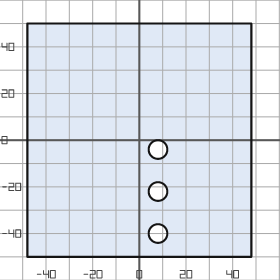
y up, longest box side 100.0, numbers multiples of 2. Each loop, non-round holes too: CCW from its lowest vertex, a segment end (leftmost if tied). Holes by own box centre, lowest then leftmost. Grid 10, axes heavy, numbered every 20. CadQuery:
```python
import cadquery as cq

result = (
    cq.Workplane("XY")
    .moveTo(-48.0, -50.0)
    .lineTo(48.0, -50.0)
    .lineTo(48.0, 50.0)
    .lineTo(-48.0, 50.0)
    .close()
    .moveTo(8.0, -40.0)
    .circle(4.0)
    .moveTo(8.0, -22.0)
    .circle(4.0)
    .moveTo(8.0, -4.0)
    .circle(4.0)
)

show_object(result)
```